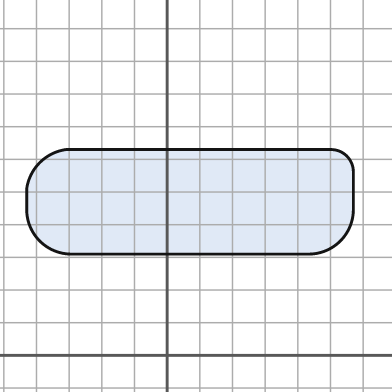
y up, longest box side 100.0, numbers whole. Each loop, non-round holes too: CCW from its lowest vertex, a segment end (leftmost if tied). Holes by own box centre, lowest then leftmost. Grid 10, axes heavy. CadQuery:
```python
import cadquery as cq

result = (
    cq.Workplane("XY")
    .moveTo(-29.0, 31.0)
    .lineTo(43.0, 31.0)
    .threePointArc((53.0, 35.0), (57.0, 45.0))
    .lineTo(57.0, 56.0)
    .threePointArc((55.0, 61.0), (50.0, 63.0))
    .lineTo(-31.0, 63.0)
    .threePointArc((-39.0, 59.0), (-43.0, 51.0))
    .lineTo(-43.0, 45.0)
    .threePointArc((-39.0, 35.0), (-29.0, 31.0))
    .close()
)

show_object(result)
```